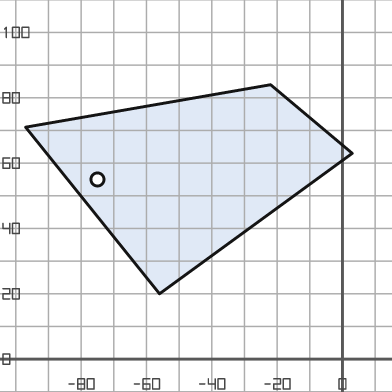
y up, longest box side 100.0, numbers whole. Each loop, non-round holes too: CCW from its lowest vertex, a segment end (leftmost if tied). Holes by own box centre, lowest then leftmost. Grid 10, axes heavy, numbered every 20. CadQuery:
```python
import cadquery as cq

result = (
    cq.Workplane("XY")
    .moveTo(-56.0, 20.0)
    .lineTo(3.0, 63.0)
    .lineTo(-22.0, 84.0)
    .lineTo(-97.0, 71.0)
    .close()
    .moveTo(-75.0, 55.0)
    .circle(2.0)
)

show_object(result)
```